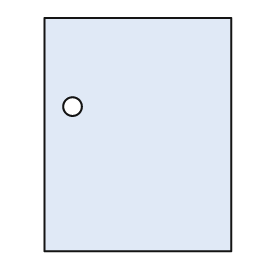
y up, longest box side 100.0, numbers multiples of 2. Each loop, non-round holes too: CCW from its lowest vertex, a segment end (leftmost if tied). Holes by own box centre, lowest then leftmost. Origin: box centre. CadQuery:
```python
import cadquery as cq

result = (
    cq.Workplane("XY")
    .moveTo(-40.0, -50.0)
    .lineTo(40.0, -50.0)
    .lineTo(40.0, 50.0)
    .lineTo(-40.0, 50.0)
    .close()
    .moveTo(-28.0, 12.0)
    .circle(4.0)
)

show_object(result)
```